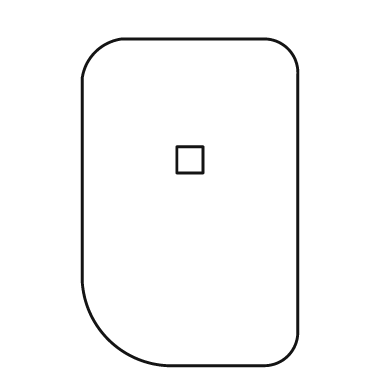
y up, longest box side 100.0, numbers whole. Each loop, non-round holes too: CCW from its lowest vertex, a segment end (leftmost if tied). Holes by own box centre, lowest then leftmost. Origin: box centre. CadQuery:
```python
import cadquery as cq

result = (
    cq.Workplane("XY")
    .moveTo(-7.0, -50.0)
    .lineTo(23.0, -50.0)
    .threePointArc((30.0, -47.0), (33.0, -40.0))
    .lineTo(33.0, 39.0)
    .threePointArc((30.0, 47.0), (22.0, 50.0))
    .lineTo(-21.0, 50.0)
    .threePointArc((-29.0, 46.0), (-33.0, 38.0))
    .lineTo(-33.0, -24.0)
    .threePointArc((-25.0, -42.0), (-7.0, -50.0))
    .close()
    .moveTo(-4.0, 9.0)
    .lineTo(4.0, 9.0)
    .lineTo(4.0, 17.0)
    .lineTo(-4.0, 17.0)
    .close()
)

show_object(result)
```